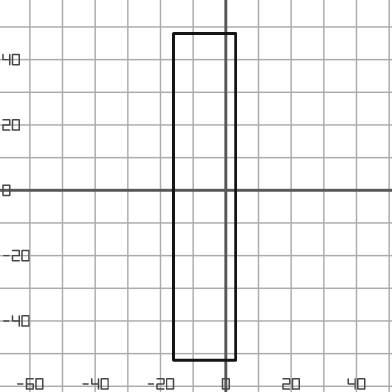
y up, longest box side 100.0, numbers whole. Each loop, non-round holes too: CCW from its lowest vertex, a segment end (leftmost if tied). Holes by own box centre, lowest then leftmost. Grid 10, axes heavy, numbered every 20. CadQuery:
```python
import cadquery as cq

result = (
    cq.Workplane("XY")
    .moveTo(-16.0, -52.0)
    .lineTo(3.0, -52.0)
    .lineTo(3.0, 48.0)
    .lineTo(-16.0, 48.0)
    .close()
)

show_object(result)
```